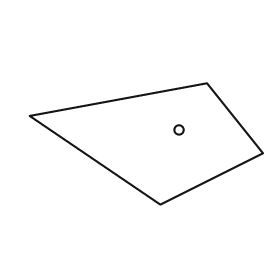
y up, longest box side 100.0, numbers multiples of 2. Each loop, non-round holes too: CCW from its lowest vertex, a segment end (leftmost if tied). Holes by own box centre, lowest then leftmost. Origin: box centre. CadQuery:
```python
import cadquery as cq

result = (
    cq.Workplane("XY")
    .moveTo(6.0, -26.0)
    .lineTo(50.0, -4.0)
    .lineTo(26.0, 26.0)
    .lineTo(-50.0, 12.0)
    .close()
    .moveTo(14.0, 6.0)
    .circle(2.0)
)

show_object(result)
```